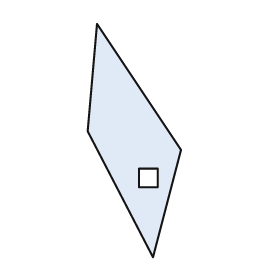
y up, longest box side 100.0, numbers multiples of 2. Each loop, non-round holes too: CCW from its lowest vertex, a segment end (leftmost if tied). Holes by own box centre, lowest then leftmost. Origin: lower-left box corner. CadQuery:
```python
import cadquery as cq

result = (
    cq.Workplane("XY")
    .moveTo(28.0, 0.0)
    .lineTo(40.0, 46.0)
    .lineTo(4.0, 100.0)
    .lineTo(0.0, 54.0)
    .close()
    .moveTo(22.0, 30.0)
    .lineTo(30.0, 30.0)
    .lineTo(30.0, 38.0)
    .lineTo(22.0, 38.0)
    .close()
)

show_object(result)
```